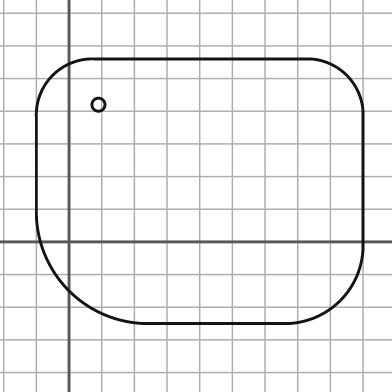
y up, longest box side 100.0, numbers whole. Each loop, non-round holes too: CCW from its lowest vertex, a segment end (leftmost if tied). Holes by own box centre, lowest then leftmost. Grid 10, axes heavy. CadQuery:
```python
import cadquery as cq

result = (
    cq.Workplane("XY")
    .moveTo(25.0, -25.0)
    .lineTo(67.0, -25.0)
    .threePointArc((83.0, -18.0), (90.0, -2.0))
    .lineTo(90.0, 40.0)
    .threePointArc((85.0, 51.0), (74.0, 56.0))
    .lineTo(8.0, 56.0)
    .threePointArc((-5.0, 51.0), (-10.0, 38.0))
    .lineTo(-10.0, 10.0)
    .threePointArc((0.0, -15.0), (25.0, -25.0))
    .close()
    .moveTo(9.0, 42.0)
    .circle(2.0)
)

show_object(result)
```